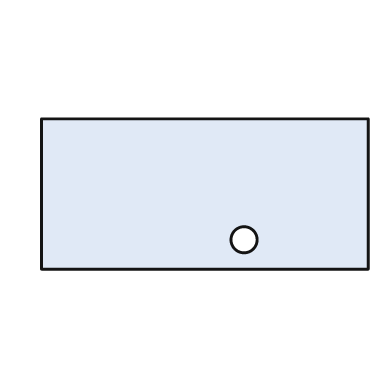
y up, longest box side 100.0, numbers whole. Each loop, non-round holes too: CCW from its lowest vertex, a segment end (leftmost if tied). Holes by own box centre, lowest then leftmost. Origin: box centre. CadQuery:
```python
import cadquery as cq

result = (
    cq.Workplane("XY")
    .moveTo(-50.0, -23.0)
    .lineTo(50.0, -23.0)
    .lineTo(50.0, 23.0)
    .lineTo(-50.0, 23.0)
    .close()
    .moveTo(12.0, -14.0)
    .circle(4.0)
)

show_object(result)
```